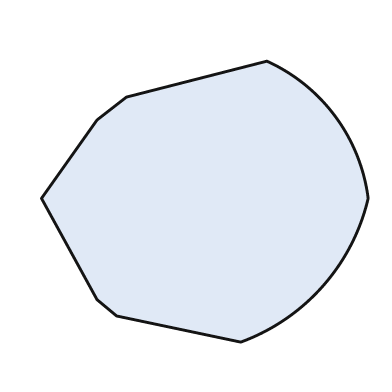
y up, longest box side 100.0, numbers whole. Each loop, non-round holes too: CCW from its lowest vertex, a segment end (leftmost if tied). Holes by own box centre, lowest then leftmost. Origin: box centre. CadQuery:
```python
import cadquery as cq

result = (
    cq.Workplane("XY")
    .moveTo(11.0, -43.0)
    .threePointArc((36.0, -26.0), (50.0, 1.0))
    .threePointArc((40.0, 26.0), (19.0, 43.0))
    .lineTo(-24.0, 32.0)
    .lineTo(-33.0, 25.0)
    .lineTo(-50.0, 1.0)
    .lineTo(-33.0, -30.0)
    .lineTo(-27.0, -35.0)
    .close()
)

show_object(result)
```